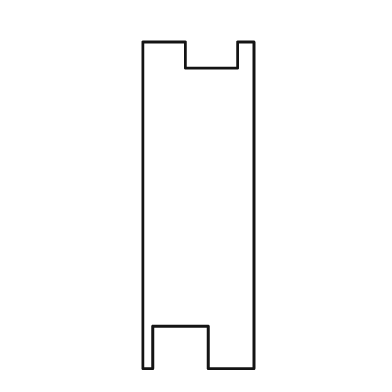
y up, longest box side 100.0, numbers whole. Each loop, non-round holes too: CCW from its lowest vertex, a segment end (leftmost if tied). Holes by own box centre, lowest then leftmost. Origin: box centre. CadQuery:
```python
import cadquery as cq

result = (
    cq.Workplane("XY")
    .moveTo(-17.0, -50.0)
    .lineTo(-14.0, -50.0)
    .lineTo(-14.0, -37.0)
    .lineTo(3.0, -37.0)
    .lineTo(3.0, -50.0)
    .lineTo(17.0, -50.0)
    .lineTo(17.0, 50.0)
    .lineTo(12.0, 50.0)
    .lineTo(12.0, 42.0)
    .lineTo(-4.0, 42.0)
    .lineTo(-4.0, 50.0)
    .lineTo(-17.0, 50.0)
    .close()
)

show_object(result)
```